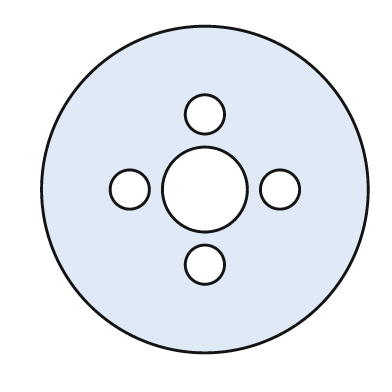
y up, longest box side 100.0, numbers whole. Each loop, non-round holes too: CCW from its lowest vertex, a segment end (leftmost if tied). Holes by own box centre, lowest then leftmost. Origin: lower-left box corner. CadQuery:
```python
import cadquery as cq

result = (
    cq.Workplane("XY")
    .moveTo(50.0, 50.0)
    .circle(50.0)
    .moveTo(50.0, 27.0)
    .circle(6.0)
    .moveTo(27.0, 50.0)
    .circle(6.0)
    .moveTo(50.0, 50.0)
    .circle(13.0)
    .moveTo(73.0, 50.0)
    .circle(6.0)
    .moveTo(50.0, 73.0)
    .circle(6.0)
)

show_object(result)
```